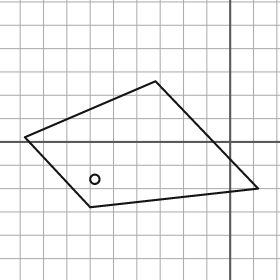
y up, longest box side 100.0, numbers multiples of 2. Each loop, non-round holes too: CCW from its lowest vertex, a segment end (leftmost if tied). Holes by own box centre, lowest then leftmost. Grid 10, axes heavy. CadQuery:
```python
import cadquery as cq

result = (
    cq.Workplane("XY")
    .moveTo(-60.0, -28.0)
    .lineTo(12.0, -20.0)
    .lineTo(-32.0, 26.0)
    .lineTo(-88.0, 2.0)
    .close()
    .moveTo(-58.0, -16.0)
    .circle(2.0)
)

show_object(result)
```